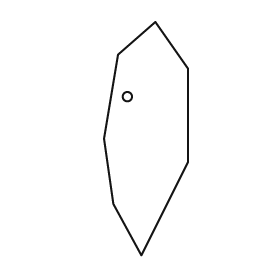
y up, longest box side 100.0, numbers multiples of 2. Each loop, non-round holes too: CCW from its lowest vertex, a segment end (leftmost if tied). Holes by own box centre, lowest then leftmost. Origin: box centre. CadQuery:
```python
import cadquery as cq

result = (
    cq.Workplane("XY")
    .moveTo(-2.0, -50.0)
    .lineTo(18.0, -10.0)
    .lineTo(18.0, 30.0)
    .lineTo(4.0, 50.0)
    .lineTo(-12.0, 36.0)
    .lineTo(-18.0, 0.0)
    .lineTo(-14.0, -28.0)
    .close()
    .moveTo(-8.0, 18.0)
    .circle(2.0)
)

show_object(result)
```